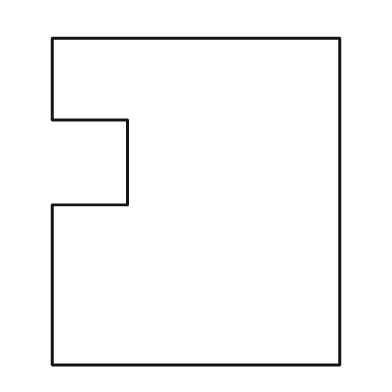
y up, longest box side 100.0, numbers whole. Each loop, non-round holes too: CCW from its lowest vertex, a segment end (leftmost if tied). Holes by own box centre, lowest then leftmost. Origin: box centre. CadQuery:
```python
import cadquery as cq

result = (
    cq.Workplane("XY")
    .moveTo(-44.0, -50.0)
    .lineTo(44.0, -50.0)
    .lineTo(44.0, 50.0)
    .lineTo(-44.0, 50.0)
    .lineTo(-44.0, 25.0)
    .lineTo(-21.0, 25.0)
    .lineTo(-21.0, -1.0)
    .lineTo(-44.0, -1.0)
    .close()
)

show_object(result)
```